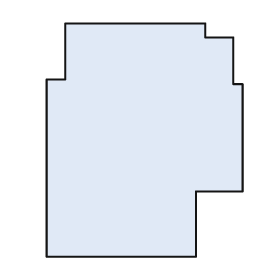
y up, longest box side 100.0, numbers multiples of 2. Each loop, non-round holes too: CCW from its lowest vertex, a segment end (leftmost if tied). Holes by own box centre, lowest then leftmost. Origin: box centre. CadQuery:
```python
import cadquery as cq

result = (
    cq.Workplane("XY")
    .moveTo(-42.0, -50.0)
    .lineTo(22.0, -50.0)
    .lineTo(22.0, -22.0)
    .lineTo(42.0, -22.0)
    .lineTo(42.0, 24.0)
    .lineTo(38.0, 24.0)
    .lineTo(38.0, 44.0)
    .lineTo(26.0, 44.0)
    .lineTo(26.0, 50.0)
    .lineTo(-34.0, 50.0)
    .lineTo(-34.0, 26.0)
    .lineTo(-42.0, 26.0)
    .close()
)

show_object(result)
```